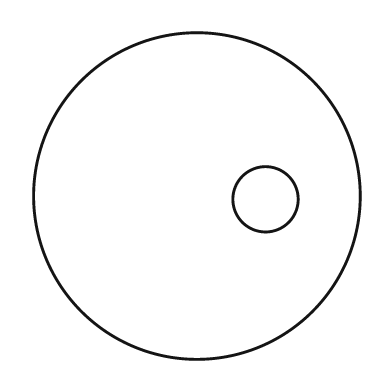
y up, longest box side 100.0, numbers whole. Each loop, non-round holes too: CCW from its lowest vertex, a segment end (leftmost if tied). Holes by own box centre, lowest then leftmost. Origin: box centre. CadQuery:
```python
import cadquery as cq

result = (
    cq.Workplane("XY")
    .moveTo(0.0, 0.0)
    .circle(50.0)
    .moveTo(21.0, -1.0)
    .circle(10.0)
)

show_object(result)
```